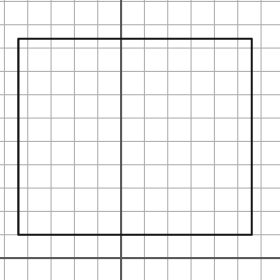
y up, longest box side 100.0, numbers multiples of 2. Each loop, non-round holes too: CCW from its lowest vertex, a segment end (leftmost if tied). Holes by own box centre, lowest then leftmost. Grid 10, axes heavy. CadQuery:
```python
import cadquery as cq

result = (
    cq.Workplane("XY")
    .moveTo(-44.0, 10.0)
    .lineTo(56.0, 10.0)
    .lineTo(56.0, 94.0)
    .lineTo(-44.0, 94.0)
    .close()
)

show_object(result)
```